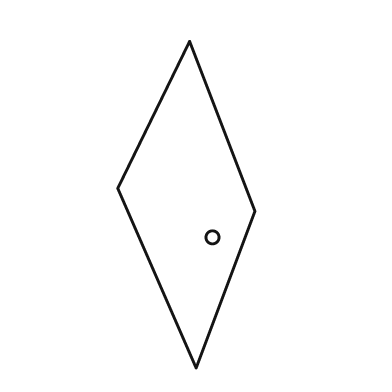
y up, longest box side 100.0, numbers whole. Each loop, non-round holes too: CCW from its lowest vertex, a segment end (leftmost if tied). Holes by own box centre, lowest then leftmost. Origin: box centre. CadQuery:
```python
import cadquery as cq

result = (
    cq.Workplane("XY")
    .moveTo(3.0, -50.0)
    .lineTo(21.0, -2.0)
    .lineTo(1.0, 50.0)
    .lineTo(-21.0, 5.0)
    .close()
    .moveTo(8.0, -10.0)
    .circle(2.0)
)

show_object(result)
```